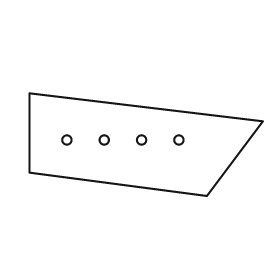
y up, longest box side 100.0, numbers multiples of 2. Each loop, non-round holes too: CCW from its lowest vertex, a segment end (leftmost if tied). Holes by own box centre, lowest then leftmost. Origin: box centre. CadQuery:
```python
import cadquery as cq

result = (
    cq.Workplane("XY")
    .moveTo(26.0, -22.0)
    .lineTo(50.0, 10.0)
    .lineTo(-50.0, 22.0)
    .lineTo(-50.0, -12.0)
    .close()
    .moveTo(-34.0, 2.0)
    .circle(2.0)
    .moveTo(-18.0, 2.0)
    .circle(2.0)
    .moveTo(-2.0, 2.0)
    .circle(2.0)
    .moveTo(14.0, 2.0)
    .circle(2.0)
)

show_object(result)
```